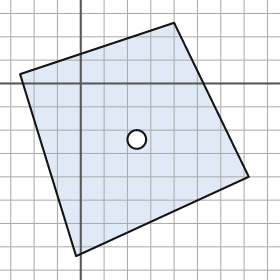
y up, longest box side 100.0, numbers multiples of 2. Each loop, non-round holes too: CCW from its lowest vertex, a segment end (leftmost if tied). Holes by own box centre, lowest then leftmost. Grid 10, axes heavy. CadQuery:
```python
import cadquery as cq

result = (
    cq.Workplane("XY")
    .moveTo(-2.0, -74.0)
    .lineTo(72.0, -40.0)
    .lineTo(40.0, 26.0)
    .lineTo(-26.0, 4.0)
    .close()
    .moveTo(24.0, -24.0)
    .circle(4.0)
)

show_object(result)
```